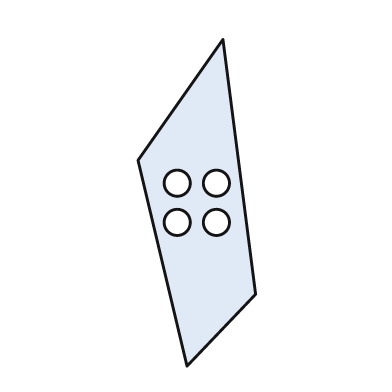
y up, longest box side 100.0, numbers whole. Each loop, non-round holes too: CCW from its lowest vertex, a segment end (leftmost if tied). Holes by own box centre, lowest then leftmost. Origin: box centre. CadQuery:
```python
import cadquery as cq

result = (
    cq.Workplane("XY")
    .moveTo(-3.0, -50.0)
    .lineTo(18.0, -28.0)
    .lineTo(8.0, 50.0)
    .lineTo(-18.0, 13.0)
    .close()
    .moveTo(-6.0, -6.0)
    .circle(4.0)
    .moveTo(6.0, -6.0)
    .circle(4.0)
    .moveTo(-6.0, 6.0)
    .circle(4.0)
    .moveTo(6.0, 6.0)
    .circle(4.0)
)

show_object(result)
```